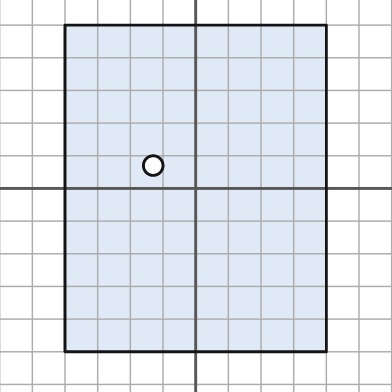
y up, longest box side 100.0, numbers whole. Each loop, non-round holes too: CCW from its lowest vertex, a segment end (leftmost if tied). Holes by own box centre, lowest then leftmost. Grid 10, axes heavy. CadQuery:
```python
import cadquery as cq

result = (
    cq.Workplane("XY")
    .moveTo(-40.0, -50.0)
    .lineTo(40.0, -50.0)
    .lineTo(40.0, 50.0)
    .lineTo(-40.0, 50.0)
    .close()
    .moveTo(-13.0, 7.0)
    .circle(3.0)
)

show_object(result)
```